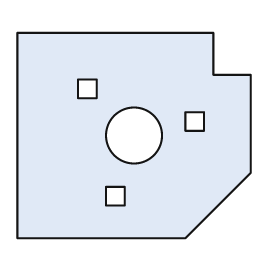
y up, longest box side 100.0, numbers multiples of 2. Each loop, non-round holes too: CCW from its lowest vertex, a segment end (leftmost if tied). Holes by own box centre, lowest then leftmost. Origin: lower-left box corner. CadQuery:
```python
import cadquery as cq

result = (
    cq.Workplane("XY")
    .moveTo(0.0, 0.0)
    .lineTo(72.0, 0.0)
    .lineTo(100.0, 28.0)
    .lineTo(100.0, 70.0)
    .lineTo(84.0, 70.0)
    .lineTo(84.0, 88.0)
    .lineTo(0.0, 88.0)
    .close()
    .moveTo(38.0, 14.0)
    .lineTo(46.0, 14.0)
    .lineTo(46.0, 22.0)
    .lineTo(38.0, 22.0)
    .close()
    .moveTo(50.0, 44.0)
    .circle(12.0)
    .moveTo(72.0, 46.0)
    .lineTo(80.0, 46.0)
    .lineTo(80.0, 54.0)
    .lineTo(72.0, 54.0)
    .close()
    .moveTo(26.0, 60.0)
    .lineTo(34.0, 60.0)
    .lineTo(34.0, 68.0)
    .lineTo(26.0, 68.0)
    .close()
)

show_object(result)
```